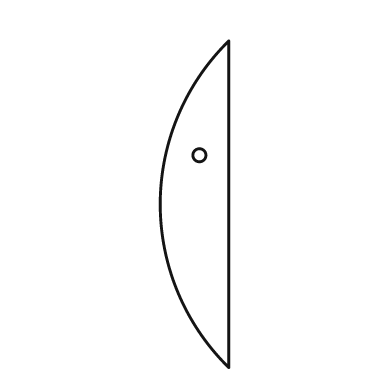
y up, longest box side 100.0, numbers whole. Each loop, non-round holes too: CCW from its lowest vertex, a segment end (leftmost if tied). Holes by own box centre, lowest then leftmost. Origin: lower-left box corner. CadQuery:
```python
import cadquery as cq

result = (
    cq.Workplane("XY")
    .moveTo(21.0, 0.0)
    .lineTo(21.0, 100.0)
    .threePointArc((0.0, 50.0), (21.0, 0.0))
    .close()
    .moveTo(12.0, 65.0)
    .circle(2.0)
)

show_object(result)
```